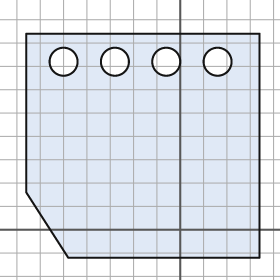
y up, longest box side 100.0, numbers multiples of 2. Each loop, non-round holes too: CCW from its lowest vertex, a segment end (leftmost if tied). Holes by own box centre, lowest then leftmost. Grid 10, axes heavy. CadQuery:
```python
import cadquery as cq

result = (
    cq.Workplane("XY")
    .moveTo(-48.0, -12.0)
    .lineTo(34.0, -12.0)
    .lineTo(34.0, 84.0)
    .lineTo(-66.0, 84.0)
    .lineTo(-66.0, 16.0)
    .close()
    .moveTo(-50.0, 72.0)
    .circle(6.0)
    .moveTo(-28.0, 72.0)
    .circle(6.0)
    .moveTo(-6.0, 72.0)
    .circle(6.0)
    .moveTo(16.0, 72.0)
    .circle(6.0)
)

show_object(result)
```